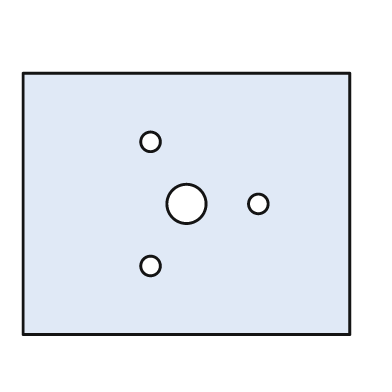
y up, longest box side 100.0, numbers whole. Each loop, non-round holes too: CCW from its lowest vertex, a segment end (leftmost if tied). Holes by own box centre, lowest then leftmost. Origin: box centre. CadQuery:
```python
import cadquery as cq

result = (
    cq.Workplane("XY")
    .moveTo(-50.0, -40.0)
    .lineTo(50.0, -40.0)
    .lineTo(50.0, 40.0)
    .lineTo(-50.0, 40.0)
    .close()
    .moveTo(-11.0, -19.0)
    .circle(3.0)
    .moveTo(0.0, 0.0)
    .circle(6.0)
    .moveTo(22.0, 0.0)
    .circle(3.0)
    .moveTo(-11.0, 19.0)
    .circle(3.0)
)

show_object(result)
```